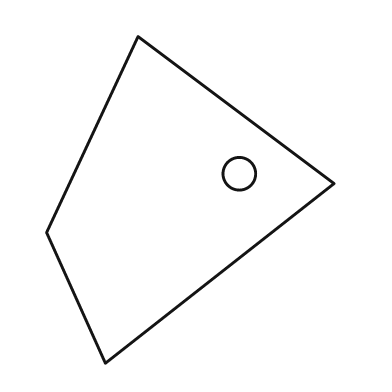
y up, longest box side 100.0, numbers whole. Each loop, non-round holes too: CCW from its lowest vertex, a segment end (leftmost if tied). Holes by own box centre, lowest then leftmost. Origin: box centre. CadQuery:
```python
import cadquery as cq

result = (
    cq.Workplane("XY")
    .moveTo(-26.0, -50.0)
    .lineTo(44.0, 5.0)
    .lineTo(-16.0, 50.0)
    .lineTo(-44.0, -10.0)
    .close()
    .moveTo(15.0, 8.0)
    .circle(5.0)
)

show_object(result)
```